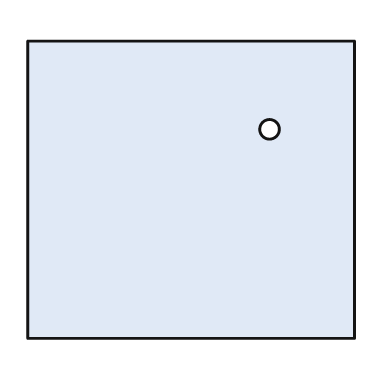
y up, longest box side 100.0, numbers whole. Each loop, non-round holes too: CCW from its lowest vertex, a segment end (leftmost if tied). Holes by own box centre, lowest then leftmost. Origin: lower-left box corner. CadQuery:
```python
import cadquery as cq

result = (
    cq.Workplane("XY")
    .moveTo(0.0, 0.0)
    .lineTo(100.0, 0.0)
    .lineTo(100.0, 91.0)
    .lineTo(0.0, 91.0)
    .close()
    .moveTo(74.0, 64.0)
    .circle(3.0)
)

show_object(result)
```